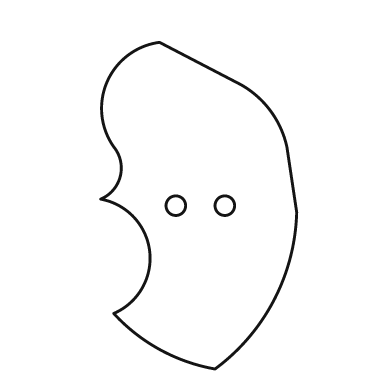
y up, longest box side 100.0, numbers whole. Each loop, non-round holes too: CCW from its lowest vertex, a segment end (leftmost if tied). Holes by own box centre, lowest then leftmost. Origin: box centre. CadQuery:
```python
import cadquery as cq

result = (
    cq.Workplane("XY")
    .moveTo(5.0, -50.0)
    .threePointArc((23.0, -29.0), (30.0, -2.0))
    .lineTo(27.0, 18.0)
    .threePointArc((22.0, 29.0), (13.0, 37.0))
    .lineTo(-12.0, 50.0)
    .threePointArc((-28.0, 38.0), (-26.0, 18.0))
    .threePointArc((-24.0, 9.0), (-30.0, 2.0))
    .threePointArc((-15.0, -14.0), (-26.0, -33.0))
    .threePointArc((-12.0, -44.0), (5.0, -50.0))
    .close()
    .moveTo(-7.0, 0.0)
    .circle(3.0)
    .moveTo(8.0, 0.0)
    .circle(3.0)
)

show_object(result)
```